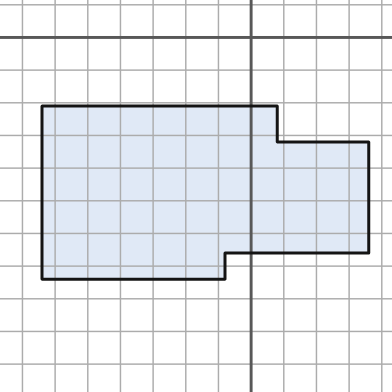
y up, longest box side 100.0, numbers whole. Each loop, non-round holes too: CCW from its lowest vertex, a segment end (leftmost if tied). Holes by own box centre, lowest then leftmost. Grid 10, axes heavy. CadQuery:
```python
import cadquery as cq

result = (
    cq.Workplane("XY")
    .moveTo(-64.0, -74.0)
    .lineTo(-8.0, -74.0)
    .lineTo(-8.0, -66.0)
    .lineTo(36.0, -66.0)
    .lineTo(36.0, -32.0)
    .lineTo(8.0, -32.0)
    .lineTo(8.0, -21.0)
    .lineTo(-64.0, -21.0)
    .close()
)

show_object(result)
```